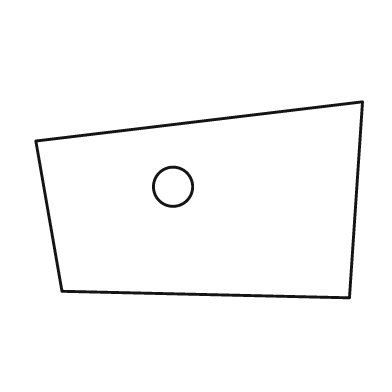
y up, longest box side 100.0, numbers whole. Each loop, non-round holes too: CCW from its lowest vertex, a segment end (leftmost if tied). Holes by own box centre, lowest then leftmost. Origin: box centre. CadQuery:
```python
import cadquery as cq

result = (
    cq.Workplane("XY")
    .moveTo(46.0, -30.0)
    .lineTo(50.0, 30.0)
    .lineTo(-50.0, 18.0)
    .lineTo(-42.0, -28.0)
    .close()
    .moveTo(-8.0, 4.0)
    .circle(6.0)
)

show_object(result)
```